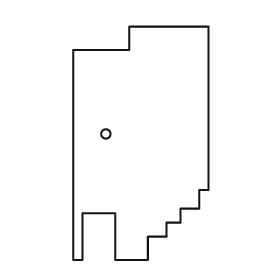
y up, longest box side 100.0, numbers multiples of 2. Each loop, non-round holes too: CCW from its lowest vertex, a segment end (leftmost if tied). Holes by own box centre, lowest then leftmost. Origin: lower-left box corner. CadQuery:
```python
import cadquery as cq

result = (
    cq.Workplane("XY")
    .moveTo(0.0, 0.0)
    .lineTo(4.0, 0.0)
    .lineTo(4.0, 20.0)
    .lineTo(18.0, 20.0)
    .lineTo(18.0, 0.0)
    .lineTo(32.0, 0.0)
    .lineTo(32.0, 10.0)
    .lineTo(40.0, 10.0)
    .lineTo(40.0, 16.0)
    .lineTo(46.0, 16.0)
    .lineTo(46.0, 22.0)
    .lineTo(54.0, 22.0)
    .lineTo(54.0, 30.0)
    .lineTo(58.0, 30.0)
    .lineTo(58.0, 100.0)
    .lineTo(24.0, 100.0)
    .lineTo(24.0, 90.0)
    .lineTo(0.0, 90.0)
    .close()
    .moveTo(14.0, 54.0)
    .circle(2.0)
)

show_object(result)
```